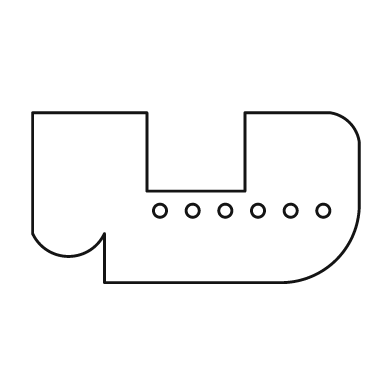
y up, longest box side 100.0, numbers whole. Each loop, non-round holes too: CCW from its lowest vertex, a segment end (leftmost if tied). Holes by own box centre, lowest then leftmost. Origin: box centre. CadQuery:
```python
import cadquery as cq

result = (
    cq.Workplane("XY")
    .moveTo(-28.0, -26.0)
    .lineTo(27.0, -26.0)
    .threePointArc((43.0, -19.0), (50.0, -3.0))
    .lineTo(50.0, 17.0)
    .threePointArc((47.0, 23.0), (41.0, 26.0))
    .lineTo(15.0, 26.0)
    .lineTo(15.0, 2.0)
    .lineTo(-15.0, 2.0)
    .lineTo(-15.0, 26.0)
    .lineTo(-50.0, 26.0)
    .lineTo(-50.0, -11.0)
    .threePointArc((-39.0, -18.0), (-28.0, -11.0))
    .close()
    .moveTo(-11.0, -4.0)
    .circle(2.0)
    .moveTo(-1.0, -4.0)
    .circle(2.0)
    .moveTo(9.0, -4.0)
    .circle(2.0)
    .moveTo(19.0, -4.0)
    .circle(2.0)
    .moveTo(29.0, -4.0)
    .circle(2.0)
    .moveTo(39.0, -4.0)
    .circle(2.0)
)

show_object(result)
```